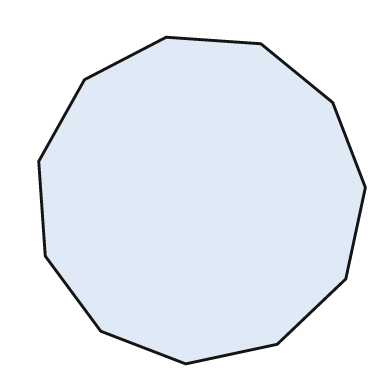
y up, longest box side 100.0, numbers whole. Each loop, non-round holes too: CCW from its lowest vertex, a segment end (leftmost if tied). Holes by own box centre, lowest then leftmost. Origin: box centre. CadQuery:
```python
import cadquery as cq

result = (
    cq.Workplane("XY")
    .moveTo(-5.0, -50.0)
    .lineTo(23.0, -44.0)
    .lineTo(44.0, -24.0)
    .lineTo(50.0, 4.0)
    .lineTo(40.0, 30.0)
    .lineTo(18.0, 48.0)
    .lineTo(-11.0, 50.0)
    .lineTo(-36.0, 37.0)
    .lineTo(-50.0, 12.0)
    .lineTo(-48.0, -17.0)
    .lineTo(-31.0, -40.0)
    .close()
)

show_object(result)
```